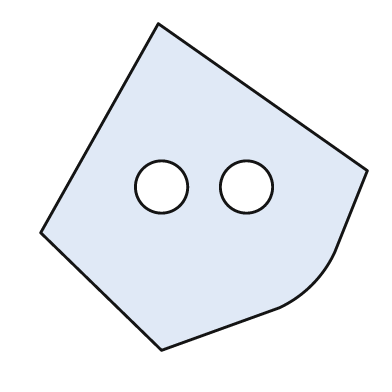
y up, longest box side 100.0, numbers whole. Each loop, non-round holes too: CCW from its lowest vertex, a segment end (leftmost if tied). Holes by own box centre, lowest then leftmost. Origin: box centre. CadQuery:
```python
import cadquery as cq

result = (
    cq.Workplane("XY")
    .moveTo(-13.0, -50.0)
    .lineTo(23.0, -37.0)
    .threePointArc((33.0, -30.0), (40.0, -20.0))
    .lineTo(50.0, 5.0)
    .lineTo(-14.0, 50.0)
    .lineTo(-50.0, -14.0)
    .close()
    .moveTo(-13.0, 0.0)
    .circle(8.0)
    .moveTo(13.0, 0.0)
    .circle(8.0)
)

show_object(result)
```